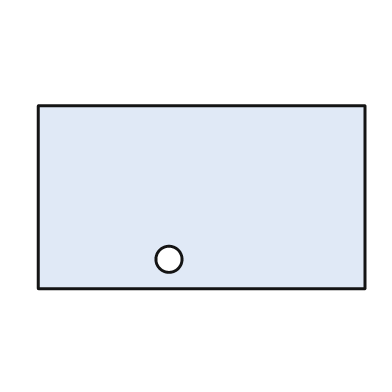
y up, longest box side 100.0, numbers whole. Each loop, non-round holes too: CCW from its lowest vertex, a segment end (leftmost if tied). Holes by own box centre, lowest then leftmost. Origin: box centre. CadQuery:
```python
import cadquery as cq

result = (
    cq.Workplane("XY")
    .moveTo(-50.0, -28.0)
    .lineTo(50.0, -28.0)
    .lineTo(50.0, 28.0)
    .lineTo(-50.0, 28.0)
    .close()
    .moveTo(-10.0, -19.0)
    .circle(4.0)
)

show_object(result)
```